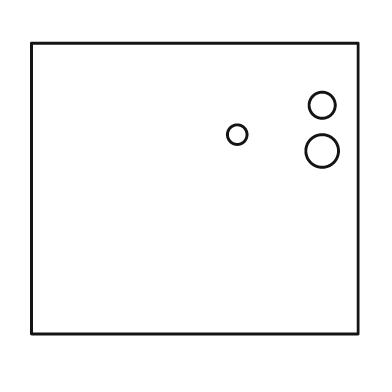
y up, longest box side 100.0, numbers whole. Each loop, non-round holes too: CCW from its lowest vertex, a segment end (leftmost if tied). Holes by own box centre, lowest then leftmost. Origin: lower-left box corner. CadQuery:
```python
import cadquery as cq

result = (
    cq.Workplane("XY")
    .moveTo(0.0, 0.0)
    .lineTo(100.0, 0.0)
    .lineTo(100.0, 89.0)
    .lineTo(0.0, 89.0)
    .close()
    .moveTo(89.0, 56.0)
    .circle(5.0)
    .moveTo(63.0, 61.0)
    .circle(3.0)
    .moveTo(89.0, 70.0)
    .circle(4.0)
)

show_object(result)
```